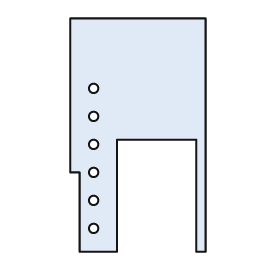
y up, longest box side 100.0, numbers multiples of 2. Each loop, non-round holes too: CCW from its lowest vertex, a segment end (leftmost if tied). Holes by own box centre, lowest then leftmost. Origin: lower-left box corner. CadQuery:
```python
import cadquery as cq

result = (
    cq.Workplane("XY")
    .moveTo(4.0, 0.0)
    .lineTo(20.0, 0.0)
    .lineTo(20.0, 48.0)
    .lineTo(54.0, 48.0)
    .lineTo(54.0, 0.0)
    .lineTo(58.0, 0.0)
    .lineTo(58.0, 100.0)
    .lineTo(0.0, 100.0)
    .lineTo(0.0, 34.0)
    .lineTo(4.0, 34.0)
    .close()
    .moveTo(10.0, 10.0)
    .circle(2.0)
    .moveTo(10.0, 22.0)
    .circle(2.0)
    .moveTo(10.0, 34.0)
    .circle(2.0)
    .moveTo(10.0, 46.0)
    .circle(2.0)
    .moveTo(10.0, 58.0)
    .circle(2.0)
    .moveTo(10.0, 70.0)
    .circle(2.0)
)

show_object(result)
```